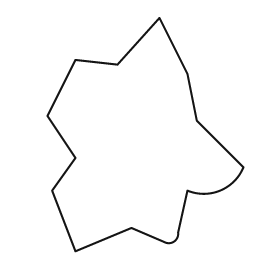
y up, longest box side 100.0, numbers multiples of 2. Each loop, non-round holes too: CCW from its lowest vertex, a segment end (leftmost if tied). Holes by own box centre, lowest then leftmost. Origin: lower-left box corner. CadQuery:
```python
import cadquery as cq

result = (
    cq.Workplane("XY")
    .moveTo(12.0, 0.0)
    .lineTo(36.0, 10.0)
    .lineTo(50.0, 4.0)
    .threePointArc((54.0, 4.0), (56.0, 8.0))
    .lineTo(60.0, 26.0)
    .threePointArc((74.0, 26.0), (84.0, 36.0))
    .lineTo(64.0, 56.0)
    .lineTo(60.0, 76.0)
    .lineTo(48.0, 100.0)
    .lineTo(30.0, 80.0)
    .lineTo(12.0, 82.0)
    .lineTo(0.0, 58.0)
    .lineTo(12.0, 40.0)
    .lineTo(2.0, 26.0)
    .close()
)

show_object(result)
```